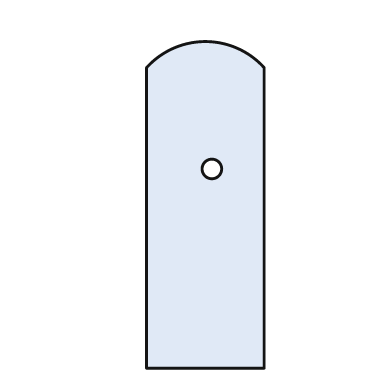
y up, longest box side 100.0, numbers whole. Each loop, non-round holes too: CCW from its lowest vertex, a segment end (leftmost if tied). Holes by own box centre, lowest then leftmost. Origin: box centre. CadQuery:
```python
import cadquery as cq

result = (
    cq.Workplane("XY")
    .moveTo(-18.0, -50.0)
    .lineTo(18.0, -50.0)
    .lineTo(18.0, 42.0)
    .threePointArc((0.0, 50.0), (-18.0, 42.0))
    .close()
    .moveTo(2.0, 11.0)
    .circle(3.0)
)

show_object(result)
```